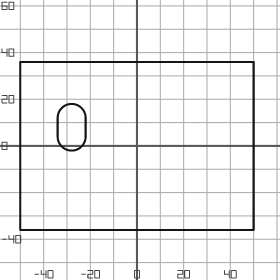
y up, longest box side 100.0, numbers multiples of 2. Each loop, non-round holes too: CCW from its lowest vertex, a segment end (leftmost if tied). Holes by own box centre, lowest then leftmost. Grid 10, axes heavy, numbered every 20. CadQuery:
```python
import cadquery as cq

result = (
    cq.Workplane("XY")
    .moveTo(-50.0, -36.0)
    .lineTo(50.0, -36.0)
    .lineTo(50.0, 36.0)
    .lineTo(-50.0, 36.0)
    .close()
    .moveTo(-34.0, 4.0)
    .threePointArc((-28.0, -2.0), (-22.0, 4.0))
    .lineTo(-22.0, 12.0)
    .threePointArc((-28.0, 18.0), (-34.0, 12.0))
    .close()
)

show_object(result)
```